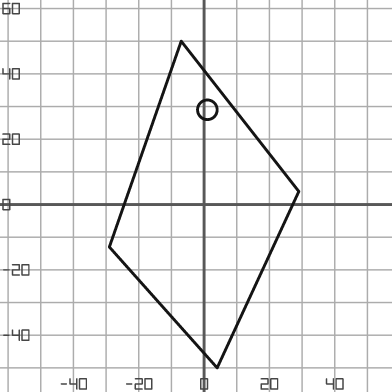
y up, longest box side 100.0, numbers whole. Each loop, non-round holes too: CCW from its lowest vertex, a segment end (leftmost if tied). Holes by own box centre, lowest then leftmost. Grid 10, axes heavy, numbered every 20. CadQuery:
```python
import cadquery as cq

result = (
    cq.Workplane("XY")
    .moveTo(4.0, -50.0)
    .lineTo(29.0, 4.0)
    .lineTo(-7.0, 50.0)
    .lineTo(-29.0, -13.0)
    .close()
    .moveTo(1.0, 29.0)
    .circle(3.0)
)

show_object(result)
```